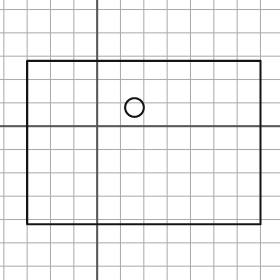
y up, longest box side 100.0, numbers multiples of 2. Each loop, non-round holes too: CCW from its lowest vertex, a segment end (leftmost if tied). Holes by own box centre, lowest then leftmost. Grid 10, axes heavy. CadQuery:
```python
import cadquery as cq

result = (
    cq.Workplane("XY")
    .moveTo(-30.0, -42.0)
    .lineTo(70.0, -42.0)
    .lineTo(70.0, 28.0)
    .lineTo(-30.0, 28.0)
    .close()
    .moveTo(16.0, 8.0)
    .circle(4.0)
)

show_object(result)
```